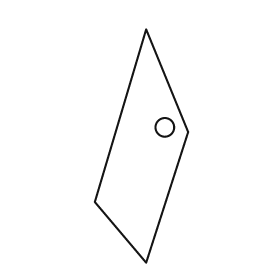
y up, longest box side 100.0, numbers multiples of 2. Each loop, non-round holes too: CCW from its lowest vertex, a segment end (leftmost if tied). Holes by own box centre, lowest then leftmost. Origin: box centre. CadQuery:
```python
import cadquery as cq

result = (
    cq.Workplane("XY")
    .moveTo(2.0, -50.0)
    .lineTo(20.0, 6.0)
    .lineTo(2.0, 50.0)
    .lineTo(-20.0, -24.0)
    .close()
    .moveTo(10.0, 8.0)
    .circle(4.0)
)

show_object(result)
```